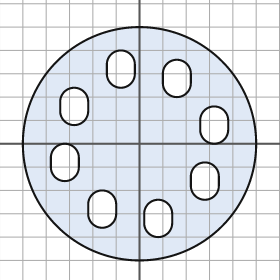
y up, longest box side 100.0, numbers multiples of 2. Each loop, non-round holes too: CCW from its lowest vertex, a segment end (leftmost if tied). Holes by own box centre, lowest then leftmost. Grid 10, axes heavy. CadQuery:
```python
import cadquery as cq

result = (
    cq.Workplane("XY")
    .moveTo(0.0, 0.0)
    .circle(50.0)
    .moveTo(2.0, -34.0)
    .threePointArc((8.0, -40.0), (14.0, -34.0))
    .lineTo(14.0, -30.0)
    .threePointArc((8.0, -24.0), (2.0, -30.0))
    .close()
    .moveTo(-22.0, -30.0)
    .threePointArc((-16.0, -36.0), (-10.0, -30.0))
    .lineTo(-10.0, -26.0)
    .threePointArc((-16.0, -20.0), (-22.0, -26.0))
    .close()
    .moveTo(22.0, -18.0)
    .threePointArc((28.0, -24.0), (34.0, -18.0))
    .lineTo(34.0, -14.0)
    .threePointArc((28.0, -8.0), (22.0, -14.0))
    .close()
    .moveTo(-38.0, -10.0)
    .threePointArc((-32.0, -16.0), (-26.0, -10.0))
    .lineTo(-26.0, -6.0)
    .threePointArc((-32.0, 0.0), (-38.0, -6.0))
    .close()
    .moveTo(26.0, 6.0)
    .threePointArc((32.0, 0.0), (38.0, 6.0))
    .lineTo(38.0, 10.0)
    .threePointArc((32.0, 16.0), (26.0, 10.0))
    .close()
    .moveTo(-34.0, 14.0)
    .threePointArc((-28.0, 8.0), (-22.0, 14.0))
    .lineTo(-22.0, 18.0)
    .threePointArc((-28.0, 24.0), (-34.0, 18.0))
    .close()
    .moveTo(10.0, 26.0)
    .threePointArc((16.0, 20.0), (22.0, 26.0))
    .lineTo(22.0, 30.0)
    .threePointArc((16.0, 36.0), (10.0, 30.0))
    .close()
    .moveTo(-14.0, 30.0)
    .threePointArc((-8.0, 24.0), (-2.0, 30.0))
    .lineTo(-2.0, 34.0)
    .threePointArc((-8.0, 40.0), (-14.0, 34.0))
    .close()
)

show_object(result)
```